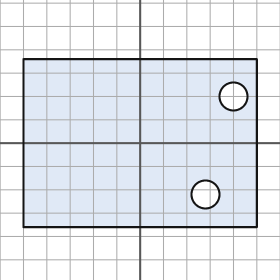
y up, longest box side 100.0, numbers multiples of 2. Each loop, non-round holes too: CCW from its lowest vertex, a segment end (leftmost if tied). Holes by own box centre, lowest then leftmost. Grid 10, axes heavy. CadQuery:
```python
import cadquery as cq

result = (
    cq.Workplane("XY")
    .moveTo(-50.0, -36.0)
    .lineTo(50.0, -36.0)
    .lineTo(50.0, 36.0)
    .lineTo(-50.0, 36.0)
    .close()
    .moveTo(28.0, -22.0)
    .circle(6.0)
    .moveTo(40.0, 20.0)
    .circle(6.0)
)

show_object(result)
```